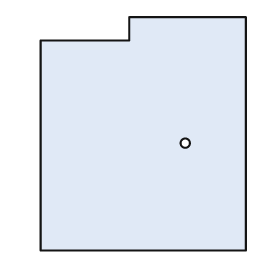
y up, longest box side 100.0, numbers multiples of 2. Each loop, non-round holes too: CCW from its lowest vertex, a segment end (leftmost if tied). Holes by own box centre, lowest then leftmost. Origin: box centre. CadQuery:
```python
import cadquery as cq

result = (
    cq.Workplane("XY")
    .moveTo(-44.0, -50.0)
    .lineTo(44.0, -50.0)
    .lineTo(44.0, 50.0)
    .lineTo(-6.0, 50.0)
    .lineTo(-6.0, 40.0)
    .lineTo(-44.0, 40.0)
    .close()
    .moveTo(18.0, -4.0)
    .circle(2.0)
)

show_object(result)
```